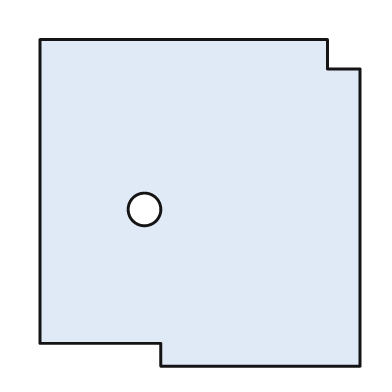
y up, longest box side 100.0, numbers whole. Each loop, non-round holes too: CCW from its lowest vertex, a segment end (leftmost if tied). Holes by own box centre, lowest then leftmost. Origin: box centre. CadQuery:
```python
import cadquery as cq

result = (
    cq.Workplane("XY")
    .moveTo(-12.0, -50.0)
    .lineTo(49.0, -50.0)
    .lineTo(49.0, 41.0)
    .lineTo(39.0, 41.0)
    .lineTo(39.0, 50.0)
    .lineTo(-49.0, 50.0)
    .lineTo(-49.0, -43.0)
    .lineTo(-12.0, -43.0)
    .close()
    .moveTo(-17.0, -2.0)
    .circle(5.0)
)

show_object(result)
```